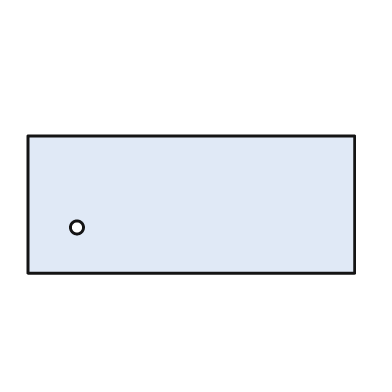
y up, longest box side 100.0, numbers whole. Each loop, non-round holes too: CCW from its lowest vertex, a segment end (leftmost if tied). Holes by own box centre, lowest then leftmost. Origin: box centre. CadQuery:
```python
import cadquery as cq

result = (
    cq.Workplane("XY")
    .moveTo(-50.0, -21.0)
    .lineTo(50.0, -21.0)
    .lineTo(50.0, 21.0)
    .lineTo(-50.0, 21.0)
    .close()
    .moveTo(-35.0, -7.0)
    .circle(2.0)
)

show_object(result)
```